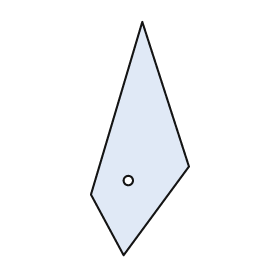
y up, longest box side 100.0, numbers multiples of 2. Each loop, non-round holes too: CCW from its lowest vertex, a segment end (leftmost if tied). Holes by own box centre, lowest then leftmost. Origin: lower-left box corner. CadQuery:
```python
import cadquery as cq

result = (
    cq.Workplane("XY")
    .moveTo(14.0, 0.0)
    .lineTo(42.0, 38.0)
    .lineTo(22.0, 100.0)
    .lineTo(0.0, 26.0)
    .close()
    .moveTo(16.0, 32.0)
    .circle(2.0)
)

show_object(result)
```